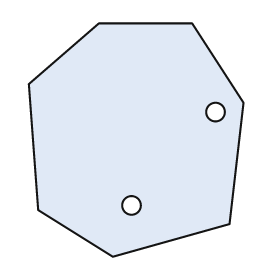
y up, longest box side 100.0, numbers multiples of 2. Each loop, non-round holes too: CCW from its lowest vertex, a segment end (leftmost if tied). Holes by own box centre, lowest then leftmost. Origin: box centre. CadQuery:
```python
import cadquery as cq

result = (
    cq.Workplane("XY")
    .moveTo(-10.0, -50.0)
    .lineTo(40.0, -36.0)
    .lineTo(46.0, 16.0)
    .lineTo(24.0, 50.0)
    .lineTo(-16.0, 50.0)
    .lineTo(-46.0, 24.0)
    .lineTo(-42.0, -30.0)
    .close()
    .moveTo(-2.0, -28.0)
    .circle(4.0)
    .moveTo(34.0, 12.0)
    .circle(4.0)
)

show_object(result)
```